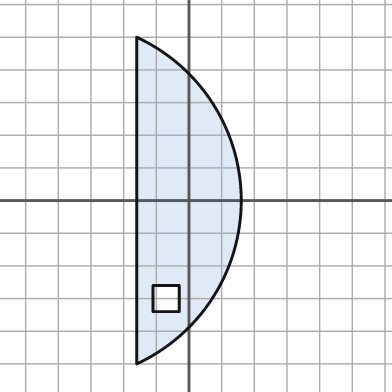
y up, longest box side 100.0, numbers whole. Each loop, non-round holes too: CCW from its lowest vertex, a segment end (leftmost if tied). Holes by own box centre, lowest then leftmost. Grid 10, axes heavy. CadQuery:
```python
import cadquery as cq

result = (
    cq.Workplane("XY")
    .moveTo(-16.0, -50.0)
    .threePointArc((16.0, 0.0), (-16.0, 50.0))
    .close()
    .moveTo(-11.0, -34.0)
    .lineTo(-3.0, -34.0)
    .lineTo(-3.0, -26.0)
    .lineTo(-11.0, -26.0)
    .close()
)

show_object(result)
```